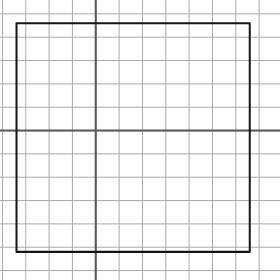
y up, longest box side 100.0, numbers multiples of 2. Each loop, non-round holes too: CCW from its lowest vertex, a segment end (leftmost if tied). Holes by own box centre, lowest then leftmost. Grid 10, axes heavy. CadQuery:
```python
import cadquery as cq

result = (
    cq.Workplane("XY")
    .moveTo(-34.0, -52.0)
    .lineTo(66.0, -52.0)
    .lineTo(66.0, 46.0)
    .lineTo(-34.0, 46.0)
    .close()
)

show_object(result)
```